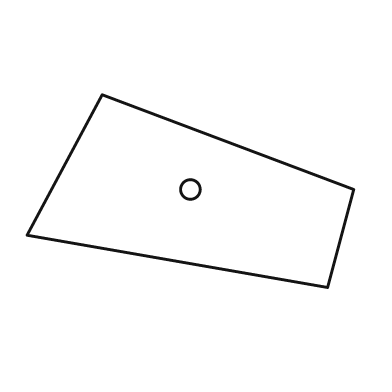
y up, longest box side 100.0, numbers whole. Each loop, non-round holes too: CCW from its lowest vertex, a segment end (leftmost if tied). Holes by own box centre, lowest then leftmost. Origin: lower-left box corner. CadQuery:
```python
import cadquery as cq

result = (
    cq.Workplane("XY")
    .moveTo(92.0, 0.0)
    .lineTo(100.0, 30.0)
    .lineTo(23.0, 59.0)
    .lineTo(0.0, 16.0)
    .close()
    .moveTo(50.0, 30.0)
    .circle(3.0)
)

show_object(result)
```